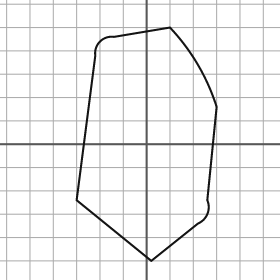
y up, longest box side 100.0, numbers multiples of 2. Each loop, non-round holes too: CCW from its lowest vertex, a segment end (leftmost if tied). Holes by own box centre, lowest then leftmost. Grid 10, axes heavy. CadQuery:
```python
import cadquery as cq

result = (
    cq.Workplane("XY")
    .moveTo(2.0, -50.0)
    .lineTo(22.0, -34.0)
    .threePointArc((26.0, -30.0), (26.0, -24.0))
    .lineTo(30.0, 16.0)
    .threePointArc((22.0, 34.0), (10.0, 50.0))
    .lineTo(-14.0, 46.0)
    .threePointArc((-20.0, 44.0), (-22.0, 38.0))
    .lineTo(-30.0, -24.0)
    .close()
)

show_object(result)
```